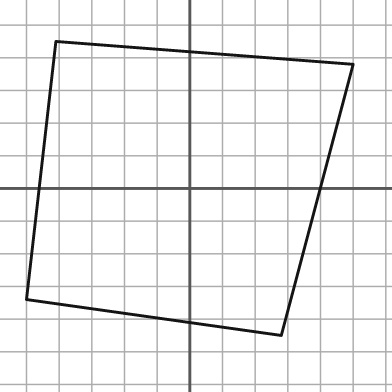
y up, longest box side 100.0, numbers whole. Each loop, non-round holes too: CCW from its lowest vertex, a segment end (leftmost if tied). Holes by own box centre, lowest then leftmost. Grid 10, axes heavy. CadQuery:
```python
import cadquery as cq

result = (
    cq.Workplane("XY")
    .moveTo(28.0, -45.0)
    .lineTo(50.0, 38.0)
    .lineTo(-41.0, 45.0)
    .lineTo(-50.0, -34.0)
    .close()
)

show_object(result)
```